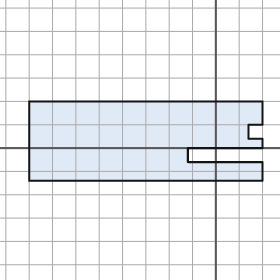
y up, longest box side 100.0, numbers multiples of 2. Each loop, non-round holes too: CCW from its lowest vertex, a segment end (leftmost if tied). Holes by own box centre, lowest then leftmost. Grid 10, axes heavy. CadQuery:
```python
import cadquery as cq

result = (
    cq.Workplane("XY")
    .moveTo(-80.0, -14.0)
    .lineTo(20.0, -14.0)
    .lineTo(20.0, -6.0)
    .lineTo(-12.0, -6.0)
    .lineTo(-12.0, 0.0)
    .lineTo(20.0, 0.0)
    .lineTo(20.0, 4.0)
    .lineTo(14.0, 4.0)
    .lineTo(14.0, 10.0)
    .lineTo(20.0, 10.0)
    .lineTo(20.0, 20.0)
    .lineTo(-80.0, 20.0)
    .close()
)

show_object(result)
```